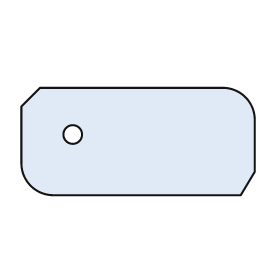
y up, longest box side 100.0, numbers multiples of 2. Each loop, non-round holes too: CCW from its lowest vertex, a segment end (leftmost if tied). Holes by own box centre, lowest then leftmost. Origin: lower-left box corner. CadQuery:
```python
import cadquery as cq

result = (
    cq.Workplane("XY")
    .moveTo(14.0, 0.0)
    .lineTo(94.0, 0.0)
    .lineTo(100.0, 10.0)
    .lineTo(100.0, 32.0)
    .threePointArc((96.0, 42.0), (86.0, 46.0))
    .lineTo(8.0, 46.0)
    .lineTo(0.0, 38.0)
    .lineTo(0.0, 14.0)
    .threePointArc((4.0, 4.0), (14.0, 0.0))
    .close()
    .moveTo(22.0, 26.0)
    .circle(4.0)
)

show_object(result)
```